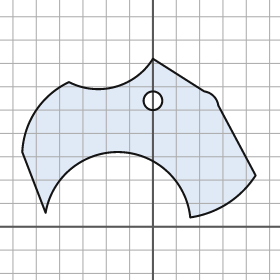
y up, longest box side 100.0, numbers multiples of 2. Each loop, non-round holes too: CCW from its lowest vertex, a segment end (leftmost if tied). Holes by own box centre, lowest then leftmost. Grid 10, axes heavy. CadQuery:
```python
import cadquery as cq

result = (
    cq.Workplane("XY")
    .moveTo(16.0, 4.0)
    .threePointArc((32.0, 10.0), (44.0, 22.0))
    .lineTo(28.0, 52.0)
    .threePointArc((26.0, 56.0), (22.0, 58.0))
    .lineTo(0.0, 72.0)
    .threePointArc((-16.0, 60.0), (-36.0, 62.0))
    .threePointArc((-50.0, 50.0), (-56.0, 32.0))
    .lineTo(-46.0, 6.0)
    .threePointArc((-14.0, 32.0), (16.0, 4.0))
    .close()
    .moveTo(0.0, 54.0)
    .circle(4.0)
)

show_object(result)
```